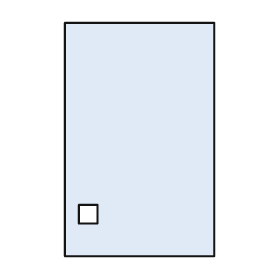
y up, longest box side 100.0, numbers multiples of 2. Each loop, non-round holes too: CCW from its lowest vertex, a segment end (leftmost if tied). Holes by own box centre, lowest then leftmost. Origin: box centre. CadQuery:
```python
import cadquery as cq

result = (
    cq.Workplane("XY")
    .moveTo(-32.0, -50.0)
    .lineTo(32.0, -50.0)
    .lineTo(32.0, 50.0)
    .lineTo(-32.0, 50.0)
    .close()
    .moveTo(-26.0, -36.0)
    .lineTo(-18.0, -36.0)
    .lineTo(-18.0, -28.0)
    .lineTo(-26.0, -28.0)
    .close()
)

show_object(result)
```